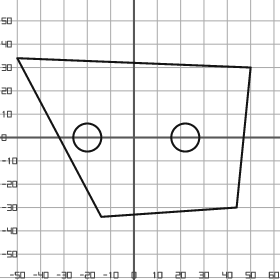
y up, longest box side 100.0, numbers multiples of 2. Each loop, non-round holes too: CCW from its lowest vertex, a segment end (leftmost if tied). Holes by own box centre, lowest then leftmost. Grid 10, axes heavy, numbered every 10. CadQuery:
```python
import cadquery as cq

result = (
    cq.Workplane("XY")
    .moveTo(-14.0, -34.0)
    .lineTo(44.0, -30.0)
    .lineTo(50.0, 30.0)
    .lineTo(-50.0, 34.0)
    .close()
    .moveTo(-20.0, 0.0)
    .circle(6.0)
    .moveTo(22.0, 0.0)
    .circle(6.0)
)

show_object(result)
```